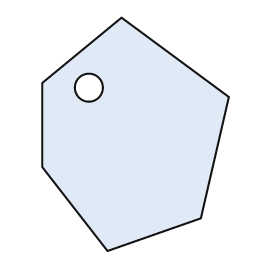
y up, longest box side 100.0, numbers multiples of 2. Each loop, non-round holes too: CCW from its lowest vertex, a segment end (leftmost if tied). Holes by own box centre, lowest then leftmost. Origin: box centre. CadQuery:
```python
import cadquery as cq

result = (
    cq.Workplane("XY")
    .moveTo(-12.0, -50.0)
    .lineTo(28.0, -36.0)
    .lineTo(40.0, 16.0)
    .lineTo(-6.0, 50.0)
    .lineTo(-40.0, 22.0)
    .lineTo(-40.0, -14.0)
    .close()
    .moveTo(-20.0, 20.0)
    .circle(6.0)
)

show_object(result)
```